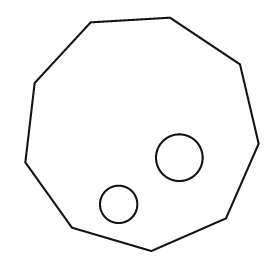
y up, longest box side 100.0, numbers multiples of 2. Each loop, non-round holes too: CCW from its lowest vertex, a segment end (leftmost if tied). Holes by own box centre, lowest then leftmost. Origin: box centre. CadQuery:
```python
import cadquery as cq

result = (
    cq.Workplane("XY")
    .moveTo(4.0, -50.0)
    .lineTo(36.0, -36.0)
    .lineTo(50.0, -4.0)
    .lineTo(42.0, 30.0)
    .lineTo(12.0, 50.0)
    .lineTo(-22.0, 48.0)
    .lineTo(-46.0, 22.0)
    .lineTo(-50.0, -12.0)
    .lineTo(-30.0, -40.0)
    .close()
    .moveTo(-10.0, -30.0)
    .circle(8.0)
    .moveTo(16.0, -10.0)
    .circle(10.0)
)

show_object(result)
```